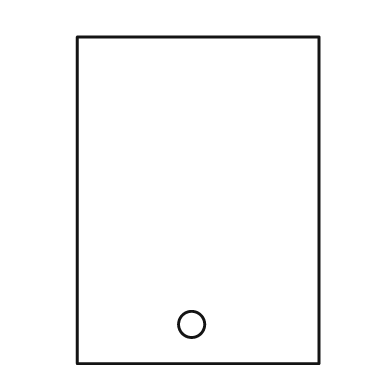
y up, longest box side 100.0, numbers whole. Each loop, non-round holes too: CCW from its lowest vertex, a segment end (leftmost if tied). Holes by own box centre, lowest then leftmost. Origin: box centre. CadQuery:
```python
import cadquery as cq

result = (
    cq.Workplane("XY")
    .moveTo(-37.0, -50.0)
    .lineTo(37.0, -50.0)
    .lineTo(37.0, 50.0)
    .lineTo(-37.0, 50.0)
    .close()
    .moveTo(-2.0, -38.0)
    .circle(4.0)
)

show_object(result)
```